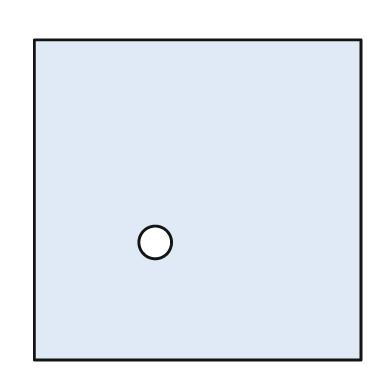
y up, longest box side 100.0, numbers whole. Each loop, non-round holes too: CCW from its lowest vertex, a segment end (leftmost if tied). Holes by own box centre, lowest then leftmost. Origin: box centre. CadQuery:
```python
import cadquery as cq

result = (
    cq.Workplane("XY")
    .moveTo(-50.0, -49.0)
    .lineTo(50.0, -49.0)
    .lineTo(50.0, 49.0)
    .lineTo(-50.0, 49.0)
    .close()
    .moveTo(-13.0, -13.0)
    .circle(5.0)
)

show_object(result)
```